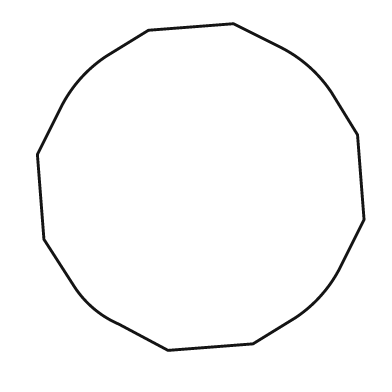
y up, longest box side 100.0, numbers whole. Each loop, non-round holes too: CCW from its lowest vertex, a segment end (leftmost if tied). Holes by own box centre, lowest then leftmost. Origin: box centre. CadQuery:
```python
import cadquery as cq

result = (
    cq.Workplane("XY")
    .moveTo(-10.0, -50.0)
    .lineTo(16.0, -48.0)
    .lineTo(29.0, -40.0)
    .threePointArc((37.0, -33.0), (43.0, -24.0))
    .lineTo(50.0, -10.0)
    .lineTo(48.0, 16.0)
    .lineTo(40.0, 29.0)
    .threePointArc((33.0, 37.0), (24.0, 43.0))
    .lineTo(10.0, 50.0)
    .lineTo(-16.0, 48.0)
    .lineTo(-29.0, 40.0)
    .threePointArc((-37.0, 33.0), (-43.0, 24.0))
    .lineTo(-50.0, 10.0)
    .lineTo(-48.0, -16.0)
    .lineTo(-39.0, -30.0)
    .threePointArc((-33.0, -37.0), (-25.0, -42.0))
    .close()
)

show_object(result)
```